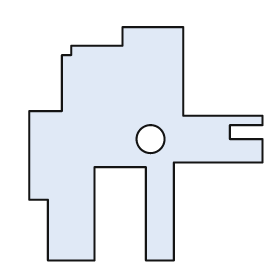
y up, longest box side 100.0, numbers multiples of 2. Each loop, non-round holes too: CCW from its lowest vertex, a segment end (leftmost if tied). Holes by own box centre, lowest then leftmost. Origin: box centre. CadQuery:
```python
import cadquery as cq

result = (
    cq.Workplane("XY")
    .moveTo(-42.0, -50.0)
    .lineTo(-22.0, -50.0)
    .lineTo(-22.0, -10.0)
    .lineTo(0.0, -10.0)
    .lineTo(0.0, -50.0)
    .lineTo(12.0, -50.0)
    .lineTo(12.0, -8.0)
    .lineTo(50.0, -8.0)
    .lineTo(50.0, 2.0)
    .lineTo(36.0, 2.0)
    .lineTo(36.0, 8.0)
    .lineTo(50.0, 8.0)
    .lineTo(50.0, 12.0)
    .lineTo(16.0, 12.0)
    .lineTo(16.0, 50.0)
    .lineTo(-10.0, 50.0)
    .lineTo(-10.0, 42.0)
    .lineTo(-32.0, 42.0)
    .lineTo(-32.0, 38.0)
    .lineTo(-36.0, 38.0)
    .lineTo(-36.0, 14.0)
    .lineTo(-50.0, 14.0)
    .lineTo(-50.0, -24.0)
    .lineTo(-42.0, -24.0)
    .close()
    .moveTo(2.0, 2.0)
    .circle(6.0)
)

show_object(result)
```